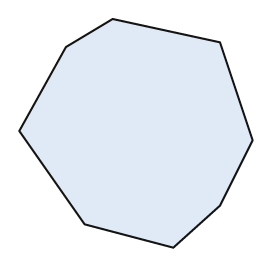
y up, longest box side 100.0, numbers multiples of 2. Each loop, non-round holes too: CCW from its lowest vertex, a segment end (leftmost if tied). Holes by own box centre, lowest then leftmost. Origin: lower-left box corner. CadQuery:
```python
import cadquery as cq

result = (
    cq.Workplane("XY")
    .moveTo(66.0, 0.0)
    .lineTo(86.0, 18.0)
    .lineTo(100.0, 46.0)
    .lineTo(86.0, 88.0)
    .lineTo(40.0, 98.0)
    .lineTo(20.0, 86.0)
    .lineTo(0.0, 50.0)
    .lineTo(28.0, 10.0)
    .close()
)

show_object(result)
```